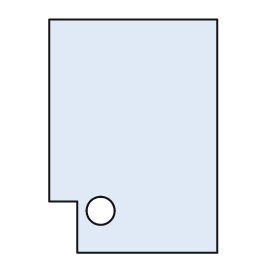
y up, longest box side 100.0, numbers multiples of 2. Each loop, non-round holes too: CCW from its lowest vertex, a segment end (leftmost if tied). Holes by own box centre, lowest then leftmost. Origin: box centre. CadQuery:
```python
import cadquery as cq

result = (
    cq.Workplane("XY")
    .moveTo(-24.0, -50.0)
    .lineTo(36.0, -50.0)
    .lineTo(36.0, 50.0)
    .lineTo(-36.0, 50.0)
    .lineTo(-36.0, -28.0)
    .lineTo(-24.0, -28.0)
    .close()
    .moveTo(-14.0, -32.0)
    .circle(6.0)
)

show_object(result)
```